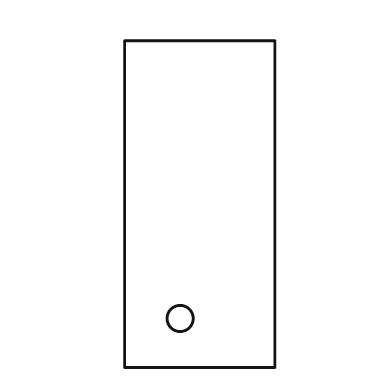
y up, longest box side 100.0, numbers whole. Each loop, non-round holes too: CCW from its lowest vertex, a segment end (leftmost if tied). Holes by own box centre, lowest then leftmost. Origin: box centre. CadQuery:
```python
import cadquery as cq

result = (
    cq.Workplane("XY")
    .moveTo(-23.0, -50.0)
    .lineTo(23.0, -50.0)
    .lineTo(23.0, 50.0)
    .lineTo(-23.0, 50.0)
    .close()
    .moveTo(-6.0, -35.0)
    .circle(4.0)
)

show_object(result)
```